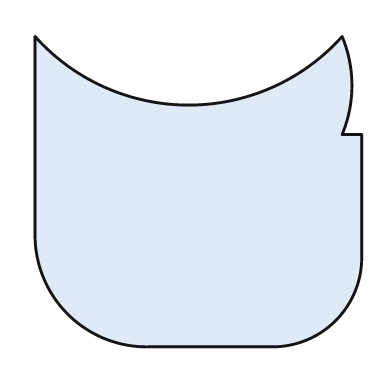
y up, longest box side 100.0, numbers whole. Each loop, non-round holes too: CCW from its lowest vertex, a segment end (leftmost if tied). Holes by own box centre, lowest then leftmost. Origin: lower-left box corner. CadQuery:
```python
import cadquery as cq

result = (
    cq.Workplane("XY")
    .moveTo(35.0, 0.0)
    .lineTo(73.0, 0.0)
    .threePointArc((92.0, 8.0), (100.0, 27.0))
    .lineTo(100.0, 65.0)
    .lineTo(94.0, 65.0)
    .threePointArc((97.0, 80.0), (94.0, 95.0))
    .threePointArc((47.0, 74.0), (0.0, 95.0))
    .lineTo(0.0, 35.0)
    .threePointArc((10.0, 10.0), (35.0, 0.0))
    .close()
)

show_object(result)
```